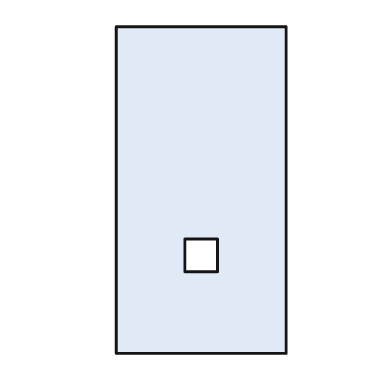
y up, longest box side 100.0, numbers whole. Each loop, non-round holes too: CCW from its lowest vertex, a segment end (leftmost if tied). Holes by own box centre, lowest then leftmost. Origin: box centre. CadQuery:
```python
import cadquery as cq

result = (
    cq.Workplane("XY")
    .moveTo(-26.0, -50.0)
    .lineTo(26.0, -50.0)
    .lineTo(26.0, 50.0)
    .lineTo(-26.0, 50.0)
    .close()
    .moveTo(-5.0, -25.0)
    .lineTo(5.0, -25.0)
    .lineTo(5.0, -15.0)
    .lineTo(-5.0, -15.0)
    .close()
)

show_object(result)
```